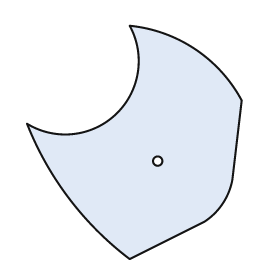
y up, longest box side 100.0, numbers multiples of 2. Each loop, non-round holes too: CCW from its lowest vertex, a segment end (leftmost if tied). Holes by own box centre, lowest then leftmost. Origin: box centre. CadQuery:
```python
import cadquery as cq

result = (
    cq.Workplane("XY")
    .moveTo(-2.0, -50.0)
    .lineTo(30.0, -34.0)
    .threePointArc((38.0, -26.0), (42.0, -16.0))
    .lineTo(46.0, 18.0)
    .threePointArc((26.0, 40.0), (-2.0, 50.0))
    .threePointArc((-8.0, 12.0), (-46.0, 8.0))
    .threePointArc((-28.0, -24.0), (-2.0, -50.0))
    .close()
    .moveTo(10.0, -8.0)
    .circle(2.0)
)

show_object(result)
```